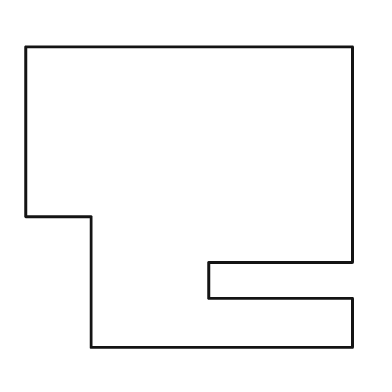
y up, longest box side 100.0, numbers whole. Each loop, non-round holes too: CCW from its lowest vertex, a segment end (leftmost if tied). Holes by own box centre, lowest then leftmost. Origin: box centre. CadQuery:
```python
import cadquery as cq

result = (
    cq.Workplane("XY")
    .moveTo(-30.0, -46.0)
    .lineTo(50.0, -46.0)
    .lineTo(50.0, -31.0)
    .lineTo(6.0, -31.0)
    .lineTo(6.0, -20.0)
    .lineTo(50.0, -20.0)
    .lineTo(50.0, 46.0)
    .lineTo(-50.0, 46.0)
    .lineTo(-50.0, -6.0)
    .lineTo(-30.0, -6.0)
    .close()
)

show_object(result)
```